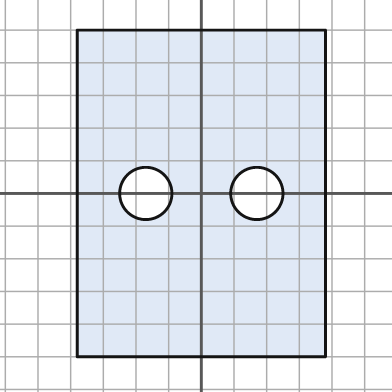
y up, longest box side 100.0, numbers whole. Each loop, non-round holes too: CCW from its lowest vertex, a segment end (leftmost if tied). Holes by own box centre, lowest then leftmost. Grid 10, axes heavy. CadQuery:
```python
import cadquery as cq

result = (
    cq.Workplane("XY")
    .moveTo(-38.0, -50.0)
    .lineTo(38.0, -50.0)
    .lineTo(38.0, 50.0)
    .lineTo(-38.0, 50.0)
    .close()
    .moveTo(-17.0, 0.0)
    .circle(8.0)
    .moveTo(17.0, 0.0)
    .circle(8.0)
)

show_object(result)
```